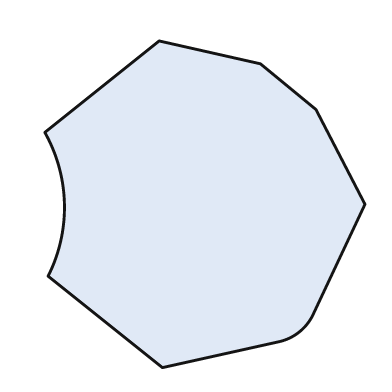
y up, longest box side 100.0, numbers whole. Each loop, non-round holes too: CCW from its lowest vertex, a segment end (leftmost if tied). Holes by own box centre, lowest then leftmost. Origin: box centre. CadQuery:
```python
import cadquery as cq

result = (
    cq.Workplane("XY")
    .moveTo(-13.0, -50.0)
    .lineTo(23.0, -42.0)
    .threePointArc((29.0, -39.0), (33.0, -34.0))
    .lineTo(49.0, 0.0)
    .lineTo(34.0, 29.0)
    .lineTo(17.0, 43.0)
    .lineTo(-14.0, 50.0)
    .lineTo(-49.0, 22.0)
    .threePointArc((-43.0, 0.0), (-48.0, -22.0))
    .close()
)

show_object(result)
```